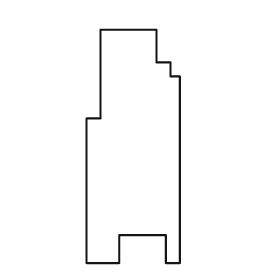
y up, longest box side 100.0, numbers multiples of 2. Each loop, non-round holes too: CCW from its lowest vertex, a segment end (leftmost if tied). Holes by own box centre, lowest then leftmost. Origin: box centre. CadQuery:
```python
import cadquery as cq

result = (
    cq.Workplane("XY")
    .moveTo(-20.0, -50.0)
    .lineTo(-6.0, -50.0)
    .lineTo(-6.0, -38.0)
    .lineTo(14.0, -38.0)
    .lineTo(14.0, -50.0)
    .lineTo(20.0, -50.0)
    .lineTo(20.0, 30.0)
    .lineTo(16.0, 30.0)
    .lineTo(16.0, 36.0)
    .lineTo(10.0, 36.0)
    .lineTo(10.0, 50.0)
    .lineTo(-14.0, 50.0)
    .lineTo(-14.0, 12.0)
    .lineTo(-20.0, 12.0)
    .close()
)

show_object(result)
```